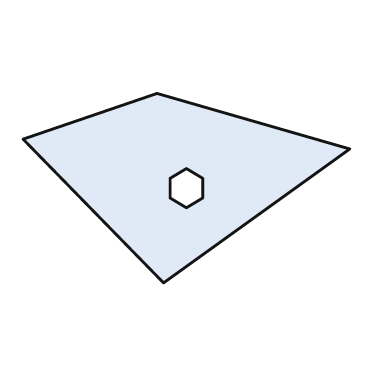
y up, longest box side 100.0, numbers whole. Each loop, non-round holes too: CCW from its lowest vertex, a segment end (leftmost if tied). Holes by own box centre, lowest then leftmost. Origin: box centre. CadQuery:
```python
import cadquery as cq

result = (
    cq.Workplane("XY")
    .moveTo(-7.0, -29.0)
    .lineTo(50.0, 12.0)
    .lineTo(-9.0, 29.0)
    .lineTo(-50.0, 15.0)
    .close()
    .moveTo(0.0, -6.0)
    .lineTo(5.0, -3.0)
    .lineTo(5.0, 3.0)
    .lineTo(0.0, 6.0)
    .lineTo(-5.0, 3.0)
    .lineTo(-5.0, -3.0)
    .close()
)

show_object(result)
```